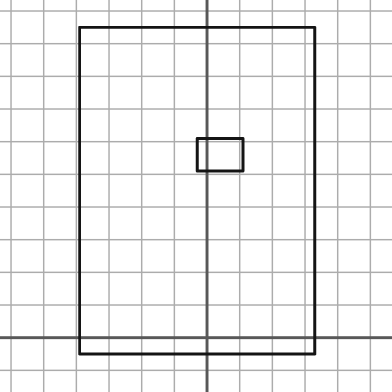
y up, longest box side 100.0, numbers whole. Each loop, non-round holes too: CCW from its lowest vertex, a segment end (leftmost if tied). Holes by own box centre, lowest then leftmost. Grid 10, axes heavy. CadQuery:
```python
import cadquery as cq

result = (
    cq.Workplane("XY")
    .moveTo(-39.0, -5.0)
    .lineTo(33.0, -5.0)
    .lineTo(33.0, 95.0)
    .lineTo(-39.0, 95.0)
    .close()
    .moveTo(-3.0, 51.0)
    .lineTo(11.0, 51.0)
    .lineTo(11.0, 61.0)
    .lineTo(-3.0, 61.0)
    .close()
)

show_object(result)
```